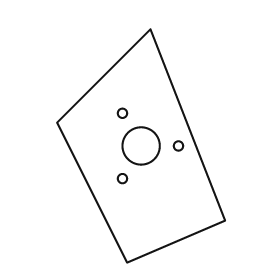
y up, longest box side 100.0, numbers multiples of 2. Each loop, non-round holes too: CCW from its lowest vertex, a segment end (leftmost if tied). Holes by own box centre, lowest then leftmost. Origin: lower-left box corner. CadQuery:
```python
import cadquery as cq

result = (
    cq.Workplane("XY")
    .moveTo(30.0, 0.0)
    .lineTo(72.0, 18.0)
    .lineTo(40.0, 100.0)
    .lineTo(0.0, 60.0)
    .close()
    .moveTo(28.0, 36.0)
    .circle(2.0)
    .moveTo(36.0, 50.0)
    .circle(8.0)
    .moveTo(52.0, 50.0)
    .circle(2.0)
    .moveTo(28.0, 64.0)
    .circle(2.0)
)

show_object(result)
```